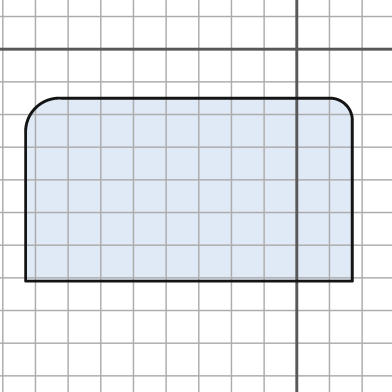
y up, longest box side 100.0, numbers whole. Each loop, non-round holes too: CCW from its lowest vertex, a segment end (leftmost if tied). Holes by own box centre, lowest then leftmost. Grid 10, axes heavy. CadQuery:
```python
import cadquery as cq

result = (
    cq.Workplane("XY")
    .moveTo(-83.0, -71.0)
    .lineTo(17.0, -71.0)
    .lineTo(17.0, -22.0)
    .threePointArc((15.0, -17.0), (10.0, -15.0))
    .lineTo(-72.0, -15.0)
    .threePointArc((-80.0, -18.0), (-83.0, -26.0))
    .close()
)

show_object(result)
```